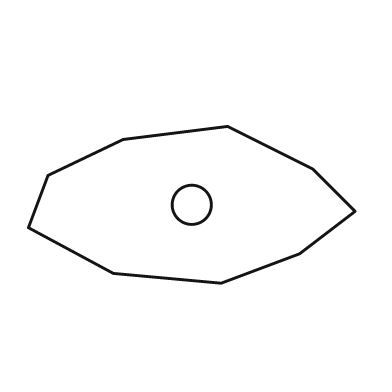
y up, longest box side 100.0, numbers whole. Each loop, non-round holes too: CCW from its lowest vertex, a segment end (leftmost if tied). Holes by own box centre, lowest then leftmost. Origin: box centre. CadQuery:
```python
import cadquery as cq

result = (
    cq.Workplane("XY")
    .moveTo(9.0, -24.0)
    .lineTo(33.0, -15.0)
    .lineTo(50.0, -2.0)
    .lineTo(37.0, 11.0)
    .lineTo(11.0, 24.0)
    .lineTo(-21.0, 20.0)
    .lineTo(-44.0, 9.0)
    .lineTo(-50.0, -7.0)
    .lineTo(-24.0, -21.0)
    .close()
    .moveTo(0.0, 0.0)
    .circle(6.0)
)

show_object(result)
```